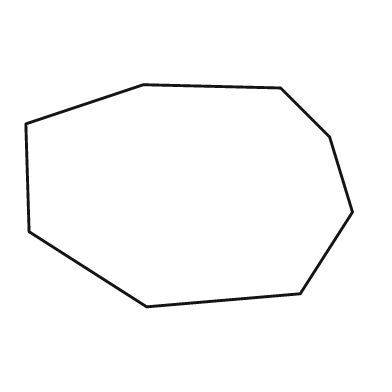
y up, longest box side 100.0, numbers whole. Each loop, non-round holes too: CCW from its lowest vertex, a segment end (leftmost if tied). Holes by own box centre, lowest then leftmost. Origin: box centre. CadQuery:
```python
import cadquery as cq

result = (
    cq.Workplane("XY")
    .moveTo(-13.0, -34.0)
    .lineTo(34.0, -30.0)
    .lineTo(50.0, -5.0)
    .lineTo(43.0, 18.0)
    .lineTo(28.0, 33.0)
    .lineTo(-14.0, 34.0)
    .lineTo(-50.0, 22.0)
    .lineTo(-49.0, -11.0)
    .close()
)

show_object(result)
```